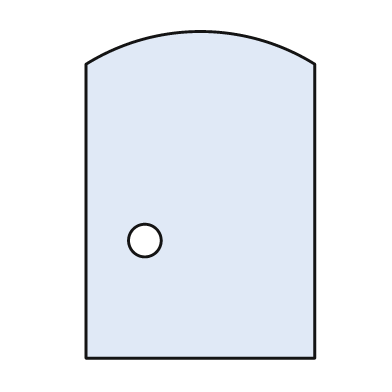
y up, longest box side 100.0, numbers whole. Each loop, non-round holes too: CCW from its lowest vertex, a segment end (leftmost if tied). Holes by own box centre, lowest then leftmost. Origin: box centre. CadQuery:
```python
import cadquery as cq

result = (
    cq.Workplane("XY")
    .moveTo(-35.0, -50.0)
    .lineTo(35.0, -50.0)
    .lineTo(35.0, 40.0)
    .threePointArc((0.0, 50.0), (-35.0, 40.0))
    .close()
    .moveTo(-17.0, -14.0)
    .circle(5.0)
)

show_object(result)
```